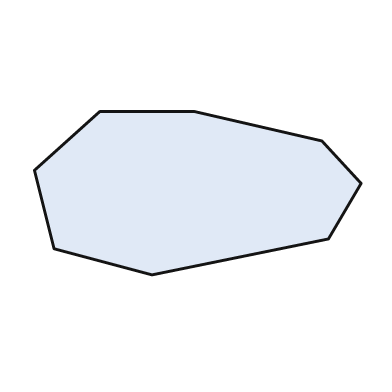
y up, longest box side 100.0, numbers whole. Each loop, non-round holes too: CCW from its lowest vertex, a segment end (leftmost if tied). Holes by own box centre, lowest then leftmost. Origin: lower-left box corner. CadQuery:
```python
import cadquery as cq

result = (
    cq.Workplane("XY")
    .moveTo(36.0, 0.0)
    .lineTo(90.0, 11.0)
    .lineTo(100.0, 28.0)
    .lineTo(88.0, 41.0)
    .lineTo(49.0, 50.0)
    .lineTo(20.0, 50.0)
    .lineTo(0.0, 32.0)
    .lineTo(6.0, 8.0)
    .close()
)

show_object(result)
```